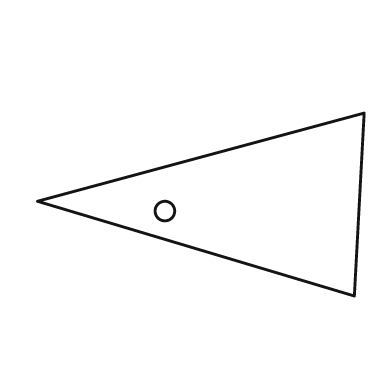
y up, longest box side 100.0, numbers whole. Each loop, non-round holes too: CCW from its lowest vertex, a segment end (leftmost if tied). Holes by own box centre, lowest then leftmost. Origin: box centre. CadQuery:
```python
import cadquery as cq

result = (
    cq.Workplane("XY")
    .moveTo(47.0, -28.0)
    .lineTo(50.0, 28.0)
    .lineTo(-50.0, 1.0)
    .close()
    .moveTo(-11.0, -2.0)
    .circle(3.0)
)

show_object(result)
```